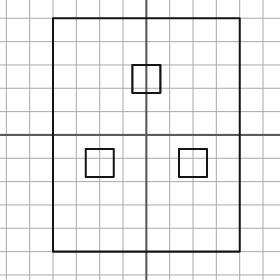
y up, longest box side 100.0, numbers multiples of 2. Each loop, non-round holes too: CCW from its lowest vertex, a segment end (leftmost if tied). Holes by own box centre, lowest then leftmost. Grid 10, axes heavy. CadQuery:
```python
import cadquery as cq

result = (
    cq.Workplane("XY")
    .moveTo(-40.0, -50.0)
    .lineTo(40.0, -50.0)
    .lineTo(40.0, 50.0)
    .lineTo(-40.0, 50.0)
    .close()
    .moveTo(-26.0, -18.0)
    .lineTo(-14.0, -18.0)
    .lineTo(-14.0, -6.0)
    .lineTo(-26.0, -6.0)
    .close()
    .moveTo(14.0, -18.0)
    .lineTo(26.0, -18.0)
    .lineTo(26.0, -6.0)
    .lineTo(14.0, -6.0)
    .close()
    .moveTo(-6.0, 18.0)
    .lineTo(6.0, 18.0)
    .lineTo(6.0, 30.0)
    .lineTo(-6.0, 30.0)
    .close()
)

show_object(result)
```